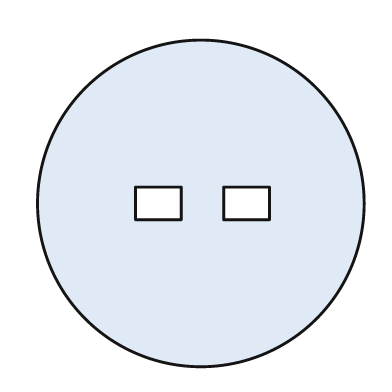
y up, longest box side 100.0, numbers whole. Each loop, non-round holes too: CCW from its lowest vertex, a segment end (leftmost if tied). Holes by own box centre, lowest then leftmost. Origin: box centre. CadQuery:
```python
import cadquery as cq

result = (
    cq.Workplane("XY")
    .moveTo(0.0, 0.0)
    .circle(50.0)
    .moveTo(-20.0, -5.0)
    .lineTo(-6.0, -5.0)
    .lineTo(-6.0, 5.0)
    .lineTo(-20.0, 5.0)
    .close()
    .moveTo(7.0, -5.0)
    .lineTo(21.0, -5.0)
    .lineTo(21.0, 5.0)
    .lineTo(7.0, 5.0)
    .close()
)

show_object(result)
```